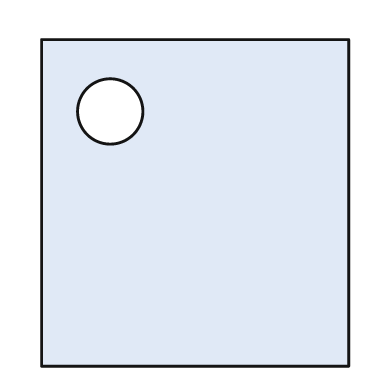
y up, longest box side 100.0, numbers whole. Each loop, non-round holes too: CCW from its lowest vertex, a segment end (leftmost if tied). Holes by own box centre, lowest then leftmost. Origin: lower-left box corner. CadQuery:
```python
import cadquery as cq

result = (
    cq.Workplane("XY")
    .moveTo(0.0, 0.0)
    .lineTo(94.0, 0.0)
    .lineTo(94.0, 100.0)
    .lineTo(0.0, 100.0)
    .close()
    .moveTo(21.0, 78.0)
    .circle(10.0)
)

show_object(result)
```